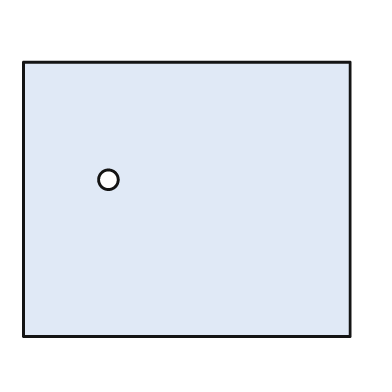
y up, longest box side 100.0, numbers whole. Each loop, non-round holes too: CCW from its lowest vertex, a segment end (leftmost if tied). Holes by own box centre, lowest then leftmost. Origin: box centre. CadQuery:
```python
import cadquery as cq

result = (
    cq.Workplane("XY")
    .moveTo(-50.0, -42.0)
    .lineTo(50.0, -42.0)
    .lineTo(50.0, 42.0)
    .lineTo(-50.0, 42.0)
    .close()
    .moveTo(-24.0, 6.0)
    .circle(3.0)
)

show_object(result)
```